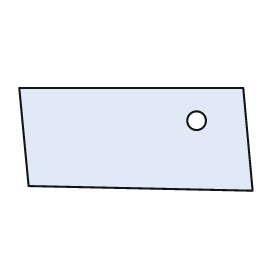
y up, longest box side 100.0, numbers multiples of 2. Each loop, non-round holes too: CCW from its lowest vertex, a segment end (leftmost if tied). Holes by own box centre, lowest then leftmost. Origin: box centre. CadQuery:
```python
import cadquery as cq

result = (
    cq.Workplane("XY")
    .moveTo(50.0, -22.0)
    .lineTo(46.0, 22.0)
    .lineTo(-50.0, 22.0)
    .lineTo(-46.0, -20.0)
    .close()
    .moveTo(26.0, 8.0)
    .circle(4.0)
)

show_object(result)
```